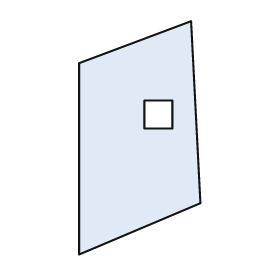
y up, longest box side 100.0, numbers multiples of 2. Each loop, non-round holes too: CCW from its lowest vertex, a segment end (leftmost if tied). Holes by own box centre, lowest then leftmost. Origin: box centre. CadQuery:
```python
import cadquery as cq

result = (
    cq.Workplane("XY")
    .moveTo(-26.0, -50.0)
    .lineTo(26.0, -28.0)
    .lineTo(22.0, 50.0)
    .lineTo(-26.0, 32.0)
    .close()
    .moveTo(2.0, 4.0)
    .lineTo(14.0, 4.0)
    .lineTo(14.0, 16.0)
    .lineTo(2.0, 16.0)
    .close()
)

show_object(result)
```